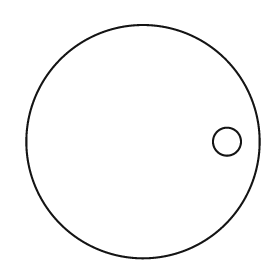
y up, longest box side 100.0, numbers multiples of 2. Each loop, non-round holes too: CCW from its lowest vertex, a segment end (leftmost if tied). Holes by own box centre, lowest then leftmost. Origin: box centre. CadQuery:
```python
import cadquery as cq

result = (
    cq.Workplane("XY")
    .moveTo(0.0, 0.0)
    .circle(50.0)
    .moveTo(36.0, 0.0)
    .circle(6.0)
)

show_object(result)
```